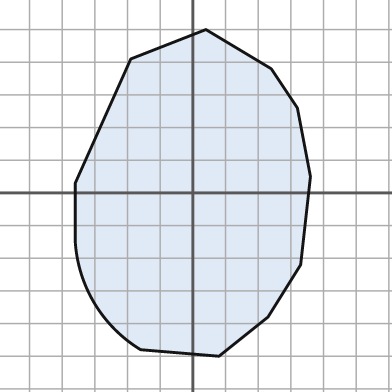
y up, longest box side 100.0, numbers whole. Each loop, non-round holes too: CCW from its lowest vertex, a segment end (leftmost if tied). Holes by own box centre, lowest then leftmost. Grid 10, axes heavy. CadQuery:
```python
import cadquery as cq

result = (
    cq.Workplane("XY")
    .moveTo(8.0, -50.0)
    .lineTo(23.0, -38.0)
    .lineTo(33.0, -22.0)
    .lineTo(36.0, 5.0)
    .lineTo(32.0, 26.0)
    .lineTo(24.0, 38.0)
    .lineTo(4.0, 50.0)
    .lineTo(-19.0, 41.0)
    .lineTo(-36.0, 3.0)
    .lineTo(-36.0, -15.0)
    .threePointArc((-30.0, -34.0), (-16.0, -48.0))
    .close()
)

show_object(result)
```